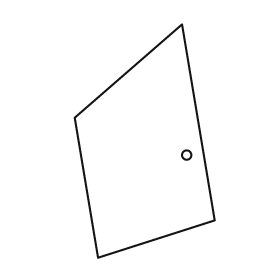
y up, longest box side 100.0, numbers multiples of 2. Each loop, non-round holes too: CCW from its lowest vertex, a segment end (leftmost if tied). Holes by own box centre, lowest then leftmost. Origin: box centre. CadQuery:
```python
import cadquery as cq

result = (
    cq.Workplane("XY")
    .moveTo(-20.0, -50.0)
    .lineTo(30.0, -34.0)
    .lineTo(16.0, 50.0)
    .lineTo(-30.0, 10.0)
    .close()
    .moveTo(18.0, -6.0)
    .circle(2.0)
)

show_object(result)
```